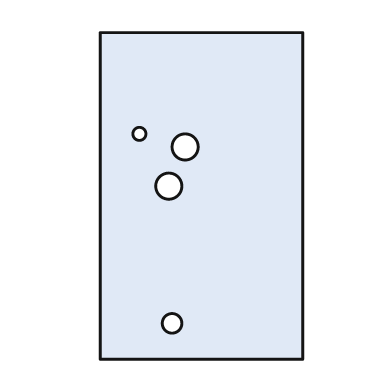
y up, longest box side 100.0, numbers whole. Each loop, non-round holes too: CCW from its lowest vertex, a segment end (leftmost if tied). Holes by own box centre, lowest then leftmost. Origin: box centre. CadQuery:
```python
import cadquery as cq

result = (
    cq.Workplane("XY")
    .moveTo(-31.0, -50.0)
    .lineTo(31.0, -50.0)
    .lineTo(31.0, 50.0)
    .lineTo(-31.0, 50.0)
    .close()
    .moveTo(-9.0, -39.0)
    .circle(3.0)
    .moveTo(-10.0, 3.0)
    .circle(4.0)
    .moveTo(-5.0, 15.0)
    .circle(4.0)
    .moveTo(-19.0, 19.0)
    .circle(2.0)
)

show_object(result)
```